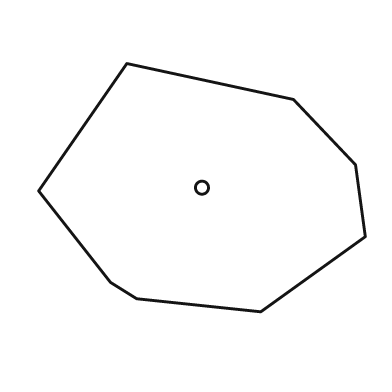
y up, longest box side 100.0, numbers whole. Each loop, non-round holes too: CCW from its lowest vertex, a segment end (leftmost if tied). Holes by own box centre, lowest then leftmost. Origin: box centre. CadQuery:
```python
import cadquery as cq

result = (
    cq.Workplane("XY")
    .moveTo(18.0, -38.0)
    .lineTo(50.0, -15.0)
    .lineTo(47.0, 7.0)
    .lineTo(28.0, 27.0)
    .lineTo(-23.0, 38.0)
    .lineTo(-50.0, -1.0)
    .lineTo(-28.0, -29.0)
    .lineTo(-20.0, -34.0)
    .close()
    .moveTo(0.0, 0.0)
    .circle(2.0)
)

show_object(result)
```